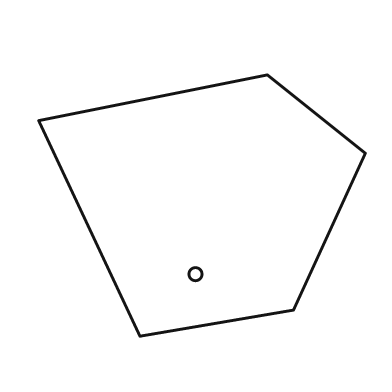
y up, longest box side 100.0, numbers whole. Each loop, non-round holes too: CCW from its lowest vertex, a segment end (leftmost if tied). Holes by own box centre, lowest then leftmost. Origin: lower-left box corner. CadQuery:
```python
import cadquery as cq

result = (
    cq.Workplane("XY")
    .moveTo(31.0, 0.0)
    .lineTo(78.0, 8.0)
    .lineTo(100.0, 56.0)
    .lineTo(70.0, 80.0)
    .lineTo(0.0, 66.0)
    .close()
    .moveTo(48.0, 19.0)
    .circle(2.0)
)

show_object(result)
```